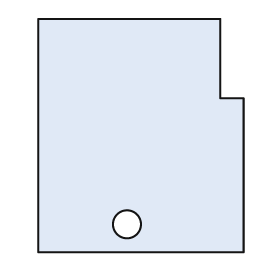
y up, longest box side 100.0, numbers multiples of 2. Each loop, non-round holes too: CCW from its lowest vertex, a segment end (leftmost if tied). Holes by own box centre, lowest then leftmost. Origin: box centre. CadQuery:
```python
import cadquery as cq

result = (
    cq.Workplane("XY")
    .moveTo(-44.0, -50.0)
    .lineTo(44.0, -50.0)
    .lineTo(44.0, 16.0)
    .lineTo(34.0, 16.0)
    .lineTo(34.0, 50.0)
    .lineTo(-44.0, 50.0)
    .close()
    .moveTo(-6.0, -38.0)
    .circle(6.0)
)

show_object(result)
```